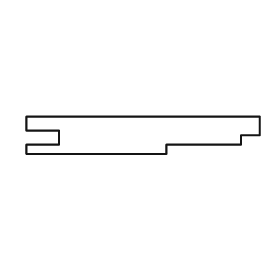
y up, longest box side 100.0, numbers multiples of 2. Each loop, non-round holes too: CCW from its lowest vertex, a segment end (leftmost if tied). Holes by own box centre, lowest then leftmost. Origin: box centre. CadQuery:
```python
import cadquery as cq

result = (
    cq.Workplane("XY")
    .moveTo(-50.0, -8.0)
    .lineTo(10.0, -8.0)
    .lineTo(10.0, -4.0)
    .lineTo(42.0, -4.0)
    .lineTo(42.0, 0.0)
    .lineTo(50.0, 0.0)
    .lineTo(50.0, 8.0)
    .lineTo(-50.0, 8.0)
    .lineTo(-50.0, 2.0)
    .lineTo(-36.0, 2.0)
    .lineTo(-36.0, -4.0)
    .lineTo(-50.0, -4.0)
    .close()
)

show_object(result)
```